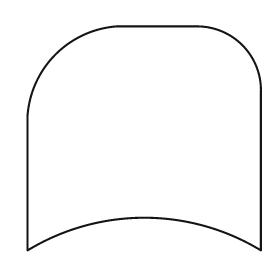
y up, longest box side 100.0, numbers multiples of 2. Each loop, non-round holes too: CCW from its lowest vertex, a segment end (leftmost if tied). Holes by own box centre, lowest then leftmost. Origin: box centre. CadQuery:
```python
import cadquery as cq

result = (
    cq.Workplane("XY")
    .moveTo(-50.0, -48.0)
    .threePointArc((0.0, -34.0), (50.0, -48.0))
    .lineTo(50.0, 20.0)
    .threePointArc((42.0, 40.0), (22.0, 48.0))
    .lineTo(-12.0, 48.0)
    .threePointArc((-38.0, 36.0), (-50.0, 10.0))
    .close()
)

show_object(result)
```